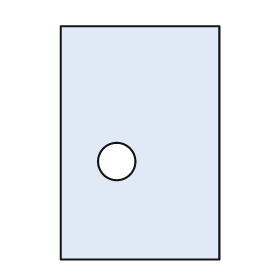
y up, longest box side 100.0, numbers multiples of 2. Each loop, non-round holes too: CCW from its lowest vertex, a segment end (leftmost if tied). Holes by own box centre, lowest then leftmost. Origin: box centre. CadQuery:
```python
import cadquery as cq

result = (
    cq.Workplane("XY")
    .moveTo(-34.0, -50.0)
    .lineTo(34.0, -50.0)
    .lineTo(34.0, 50.0)
    .lineTo(-34.0, 50.0)
    .close()
    .moveTo(-10.0, -8.0)
    .circle(8.0)
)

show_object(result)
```